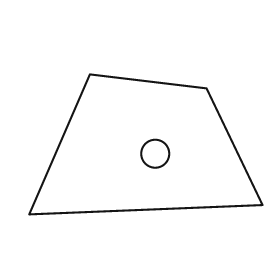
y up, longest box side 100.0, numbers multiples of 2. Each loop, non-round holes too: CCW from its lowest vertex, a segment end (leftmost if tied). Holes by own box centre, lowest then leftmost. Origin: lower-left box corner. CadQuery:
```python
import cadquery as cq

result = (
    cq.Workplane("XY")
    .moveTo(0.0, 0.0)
    .lineTo(100.0, 4.0)
    .lineTo(76.0, 54.0)
    .lineTo(26.0, 60.0)
    .close()
    .moveTo(54.0, 26.0)
    .circle(6.0)
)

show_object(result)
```